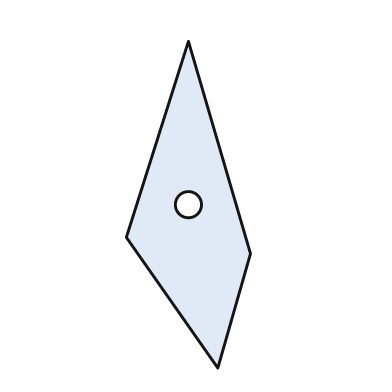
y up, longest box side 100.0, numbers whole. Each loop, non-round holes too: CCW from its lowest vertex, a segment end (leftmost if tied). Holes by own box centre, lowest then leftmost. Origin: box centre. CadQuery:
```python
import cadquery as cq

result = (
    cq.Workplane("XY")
    .moveTo(9.0, -50.0)
    .lineTo(19.0, -15.0)
    .lineTo(0.0, 50.0)
    .lineTo(-19.0, -10.0)
    .close()
    .moveTo(0.0, 0.0)
    .circle(4.0)
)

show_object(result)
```